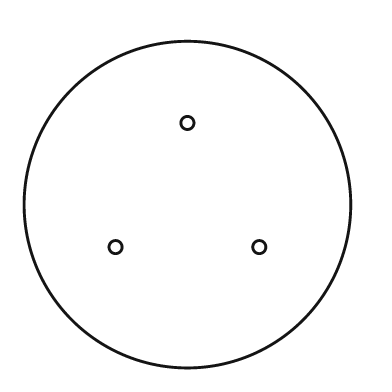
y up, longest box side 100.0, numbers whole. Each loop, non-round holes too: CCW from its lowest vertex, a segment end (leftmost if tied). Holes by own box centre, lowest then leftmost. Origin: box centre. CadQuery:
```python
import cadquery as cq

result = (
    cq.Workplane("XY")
    .moveTo(0.0, 0.0)
    .circle(50.0)
    .moveTo(-22.0, -13.0)
    .circle(2.0)
    .moveTo(22.0, -13.0)
    .circle(2.0)
    .moveTo(0.0, 25.0)
    .circle(2.0)
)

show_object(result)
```